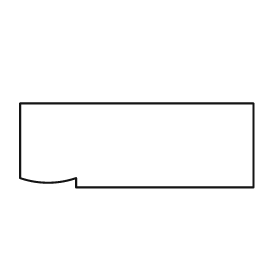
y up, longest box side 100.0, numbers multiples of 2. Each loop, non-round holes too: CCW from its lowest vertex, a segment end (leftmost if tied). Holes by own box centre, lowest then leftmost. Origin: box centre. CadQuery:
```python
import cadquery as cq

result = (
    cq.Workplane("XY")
    .moveTo(-26.0, -18.0)
    .lineTo(50.0, -18.0)
    .lineTo(50.0, 18.0)
    .lineTo(-50.0, 18.0)
    .lineTo(-50.0, -14.0)
    .threePointArc((-38.0, -16.0), (-26.0, -14.0))
    .close()
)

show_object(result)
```